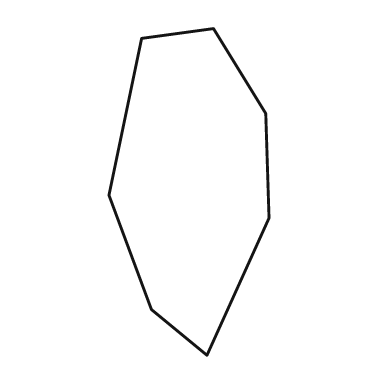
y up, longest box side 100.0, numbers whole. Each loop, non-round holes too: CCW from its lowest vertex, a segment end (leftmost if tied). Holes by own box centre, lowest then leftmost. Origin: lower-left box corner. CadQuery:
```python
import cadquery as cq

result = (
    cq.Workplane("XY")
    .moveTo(30.0, 0.0)
    .lineTo(49.0, 42.0)
    .lineTo(48.0, 74.0)
    .lineTo(32.0, 100.0)
    .lineTo(10.0, 97.0)
    .lineTo(0.0, 49.0)
    .lineTo(13.0, 14.0)
    .close()
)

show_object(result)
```